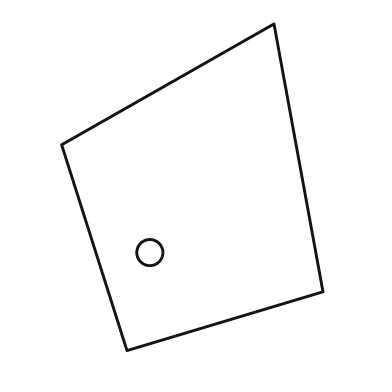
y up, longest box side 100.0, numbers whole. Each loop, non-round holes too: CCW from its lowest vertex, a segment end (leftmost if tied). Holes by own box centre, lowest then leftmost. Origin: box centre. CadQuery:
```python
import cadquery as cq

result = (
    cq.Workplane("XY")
    .moveTo(-20.0, -50.0)
    .lineTo(40.0, -32.0)
    .lineTo(25.0, 50.0)
    .lineTo(-40.0, 13.0)
    .close()
    .moveTo(-13.0, -20.0)
    .circle(4.0)
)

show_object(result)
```